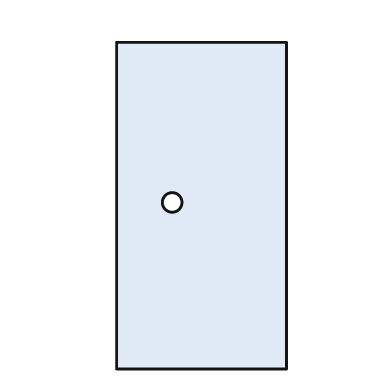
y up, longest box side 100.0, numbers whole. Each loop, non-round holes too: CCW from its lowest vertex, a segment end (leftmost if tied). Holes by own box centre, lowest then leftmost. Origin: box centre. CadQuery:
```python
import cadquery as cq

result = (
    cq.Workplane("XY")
    .moveTo(-26.0, -50.0)
    .lineTo(26.0, -50.0)
    .lineTo(26.0, 50.0)
    .lineTo(-26.0, 50.0)
    .close()
    .moveTo(-9.0, 1.0)
    .circle(3.0)
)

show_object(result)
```